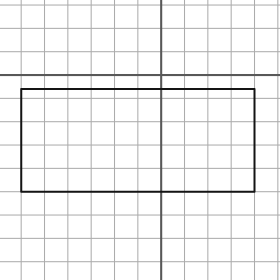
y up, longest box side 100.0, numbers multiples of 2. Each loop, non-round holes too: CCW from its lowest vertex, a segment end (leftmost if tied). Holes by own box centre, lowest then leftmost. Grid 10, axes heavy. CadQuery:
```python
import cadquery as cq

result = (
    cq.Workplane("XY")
    .moveTo(-60.0, -50.0)
    .lineTo(40.0, -50.0)
    .lineTo(40.0, -6.0)
    .lineTo(-60.0, -6.0)
    .close()
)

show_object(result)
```